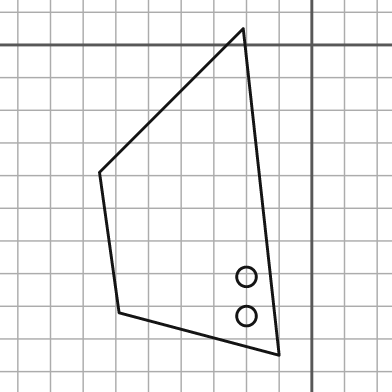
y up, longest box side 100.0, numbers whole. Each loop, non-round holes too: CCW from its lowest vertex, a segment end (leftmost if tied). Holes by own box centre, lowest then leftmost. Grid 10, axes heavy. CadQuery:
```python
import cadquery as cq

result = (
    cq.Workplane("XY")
    .moveTo(-10.0, -95.0)
    .lineTo(-21.0, 5.0)
    .lineTo(-65.0, -39.0)
    .lineTo(-59.0, -82.0)
    .close()
    .moveTo(-20.0, -83.0)
    .circle(3.0)
    .moveTo(-20.0, -71.0)
    .circle(3.0)
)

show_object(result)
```